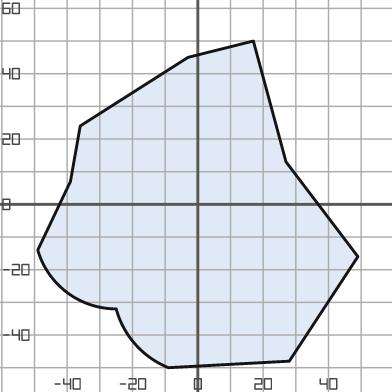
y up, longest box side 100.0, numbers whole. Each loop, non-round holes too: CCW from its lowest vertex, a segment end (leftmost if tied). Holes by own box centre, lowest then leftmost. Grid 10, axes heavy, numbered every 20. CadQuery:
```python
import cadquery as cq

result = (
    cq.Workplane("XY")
    .moveTo(-9.0, -50.0)
    .lineTo(28.0, -48.0)
    .lineTo(49.0, -16.0)
    .lineTo(27.0, 13.0)
    .lineTo(17.0, 50.0)
    .lineTo(-3.0, 45.0)
    .lineTo(-36.0, 24.0)
    .lineTo(-39.0, 7.0)
    .lineTo(-49.0, -14.0)
    .threePointArc((-40.0, -27.0), (-25.0, -32.0))
    .threePointArc((-19.0, -43.0), (-9.0, -50.0))
    .close()
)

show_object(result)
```